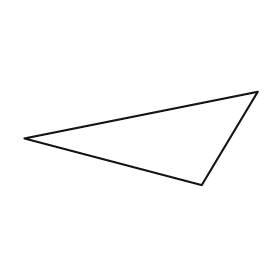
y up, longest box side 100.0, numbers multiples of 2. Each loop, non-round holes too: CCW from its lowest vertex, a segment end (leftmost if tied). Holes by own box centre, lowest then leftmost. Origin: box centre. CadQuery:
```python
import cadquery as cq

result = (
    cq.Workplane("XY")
    .moveTo(26.0, -20.0)
    .lineTo(50.0, 20.0)
    .lineTo(-50.0, 0.0)
    .close()
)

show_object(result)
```